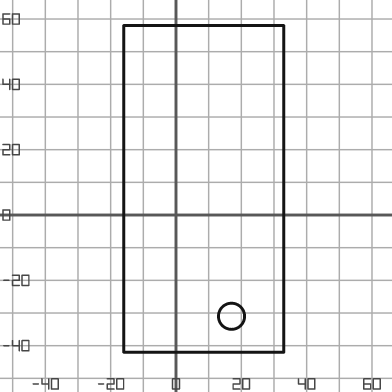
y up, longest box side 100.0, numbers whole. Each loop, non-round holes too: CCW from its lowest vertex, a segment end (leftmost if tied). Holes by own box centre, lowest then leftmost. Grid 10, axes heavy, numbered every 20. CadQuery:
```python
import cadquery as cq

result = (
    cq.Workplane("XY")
    .moveTo(-16.0, -42.0)
    .lineTo(33.0, -42.0)
    .lineTo(33.0, 58.0)
    .lineTo(-16.0, 58.0)
    .close()
    .moveTo(17.0, -31.0)
    .circle(4.0)
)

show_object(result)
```